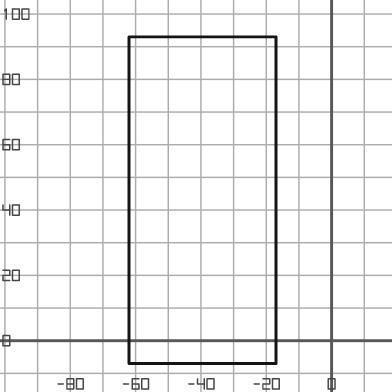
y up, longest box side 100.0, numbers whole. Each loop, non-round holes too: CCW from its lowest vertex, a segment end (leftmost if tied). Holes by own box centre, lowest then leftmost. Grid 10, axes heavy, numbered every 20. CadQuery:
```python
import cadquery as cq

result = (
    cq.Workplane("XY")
    .moveTo(-62.0, -7.0)
    .lineTo(-17.0, -7.0)
    .lineTo(-17.0, 93.0)
    .lineTo(-62.0, 93.0)
    .close()
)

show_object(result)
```